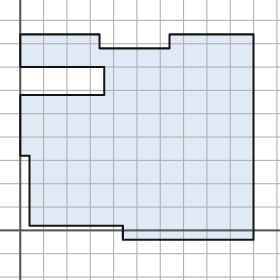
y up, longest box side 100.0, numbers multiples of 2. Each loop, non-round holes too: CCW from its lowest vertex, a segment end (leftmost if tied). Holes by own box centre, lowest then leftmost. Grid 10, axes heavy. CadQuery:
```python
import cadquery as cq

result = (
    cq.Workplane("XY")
    .moveTo(44.0, -4.0)
    .lineTo(100.0, -4.0)
    .lineTo(100.0, 84.0)
    .lineTo(64.0, 84.0)
    .lineTo(64.0, 78.0)
    .lineTo(34.0, 78.0)
    .lineTo(34.0, 84.0)
    .lineTo(0.0, 84.0)
    .lineTo(0.0, 70.0)
    .lineTo(36.0, 70.0)
    .lineTo(36.0, 58.0)
    .lineTo(0.0, 58.0)
    .lineTo(0.0, 32.0)
    .lineTo(4.0, 32.0)
    .lineTo(4.0, 2.0)
    .lineTo(44.0, 2.0)
    .close()
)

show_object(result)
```